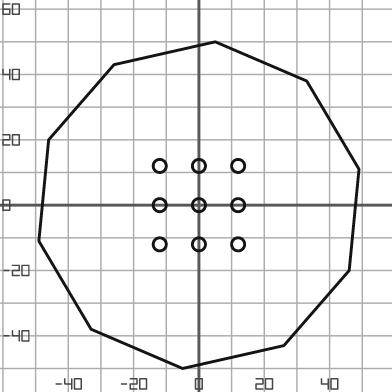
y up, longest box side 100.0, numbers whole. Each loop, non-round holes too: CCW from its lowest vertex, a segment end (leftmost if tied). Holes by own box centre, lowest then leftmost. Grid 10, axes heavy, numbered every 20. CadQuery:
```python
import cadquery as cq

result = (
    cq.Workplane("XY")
    .moveTo(-5.0, -50.0)
    .lineTo(26.0, -43.0)
    .lineTo(46.0, -20.0)
    .lineTo(49.0, 11.0)
    .lineTo(33.0, 38.0)
    .lineTo(5.0, 50.0)
    .lineTo(-26.0, 43.0)
    .lineTo(-46.0, 20.0)
    .lineTo(-49.0, -11.0)
    .lineTo(-33.0, -38.0)
    .close()
    .moveTo(-12.0, -12.0)
    .circle(2.0)
    .moveTo(0.0, -12.0)
    .circle(2.0)
    .moveTo(12.0, -12.0)
    .circle(2.0)
    .moveTo(-12.0, 0.0)
    .circle(2.0)
    .moveTo(0.0, 0.0)
    .circle(2.0)
    .moveTo(12.0, 0.0)
    .circle(2.0)
    .moveTo(-12.0, 12.0)
    .circle(2.0)
    .moveTo(0.0, 12.0)
    .circle(2.0)
    .moveTo(12.0, 12.0)
    .circle(2.0)
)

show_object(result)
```